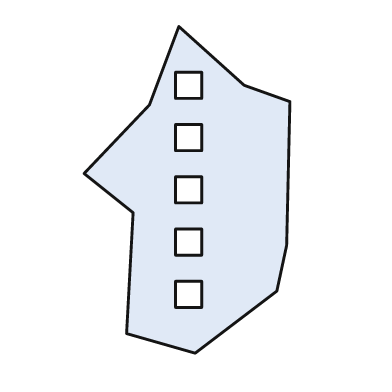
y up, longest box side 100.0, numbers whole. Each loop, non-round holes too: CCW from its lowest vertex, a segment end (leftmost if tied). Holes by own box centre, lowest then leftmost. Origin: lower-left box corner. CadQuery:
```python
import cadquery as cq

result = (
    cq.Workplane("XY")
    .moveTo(34.0, 0.0)
    .lineTo(59.0, 19.0)
    .lineTo(62.0, 33.0)
    .lineTo(63.0, 77.0)
    .lineTo(49.0, 82.0)
    .lineTo(29.0, 100.0)
    .lineTo(20.0, 76.0)
    .lineTo(0.0, 55.0)
    .lineTo(15.0, 43.0)
    .lineTo(13.0, 6.0)
    .close()
    .moveTo(28.0, 14.0)
    .lineTo(36.0, 14.0)
    .lineTo(36.0, 22.0)
    .lineTo(28.0, 22.0)
    .close()
    .moveTo(28.0, 30.0)
    .lineTo(36.0, 30.0)
    .lineTo(36.0, 38.0)
    .lineTo(28.0, 38.0)
    .close()
    .moveTo(28.0, 46.0)
    .lineTo(36.0, 46.0)
    .lineTo(36.0, 54.0)
    .lineTo(28.0, 54.0)
    .close()
    .moveTo(28.0, 62.0)
    .lineTo(36.0, 62.0)
    .lineTo(36.0, 70.0)
    .lineTo(28.0, 70.0)
    .close()
    .moveTo(28.0, 78.0)
    .lineTo(36.0, 78.0)
    .lineTo(36.0, 86.0)
    .lineTo(28.0, 86.0)
    .close()
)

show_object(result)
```